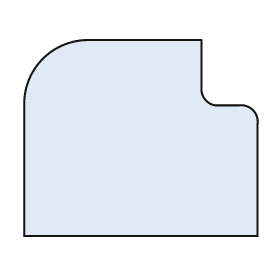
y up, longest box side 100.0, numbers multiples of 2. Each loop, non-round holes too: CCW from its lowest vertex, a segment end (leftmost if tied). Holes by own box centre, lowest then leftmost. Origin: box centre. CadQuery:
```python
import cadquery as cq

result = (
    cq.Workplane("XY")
    .moveTo(-50.0, -42.0)
    .lineTo(50.0, -42.0)
    .lineTo(50.0, 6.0)
    .threePointArc((48.0, 12.0), (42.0, 14.0))
    .lineTo(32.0, 14.0)
    .threePointArc((28.0, 16.0), (26.0, 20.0))
    .lineTo(26.0, 42.0)
    .lineTo(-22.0, 42.0)
    .threePointArc((-42.0, 34.0), (-50.0, 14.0))
    .close()
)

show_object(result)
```